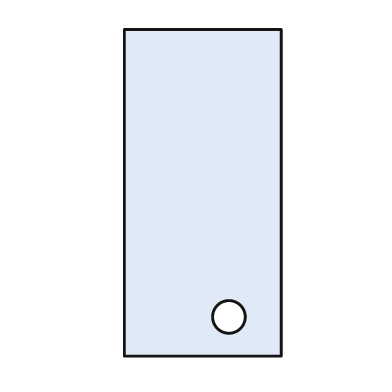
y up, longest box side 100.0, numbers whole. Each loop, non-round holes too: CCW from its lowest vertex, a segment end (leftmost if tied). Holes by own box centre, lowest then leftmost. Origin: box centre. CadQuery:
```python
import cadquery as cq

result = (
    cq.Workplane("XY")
    .moveTo(-24.0, -50.0)
    .lineTo(24.0, -50.0)
    .lineTo(24.0, 50.0)
    .lineTo(-24.0, 50.0)
    .close()
    .moveTo(8.0, -38.0)
    .circle(5.0)
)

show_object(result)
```